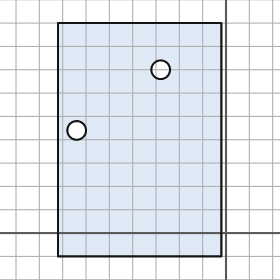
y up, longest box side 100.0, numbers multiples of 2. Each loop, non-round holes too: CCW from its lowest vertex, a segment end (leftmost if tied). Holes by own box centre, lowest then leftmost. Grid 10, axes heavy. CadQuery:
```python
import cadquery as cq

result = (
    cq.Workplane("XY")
    .moveTo(-72.0, -10.0)
    .lineTo(-2.0, -10.0)
    .lineTo(-2.0, 90.0)
    .lineTo(-72.0, 90.0)
    .close()
    .moveTo(-64.0, 44.0)
    .circle(4.0)
    .moveTo(-28.0, 70.0)
    .circle(4.0)
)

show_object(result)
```